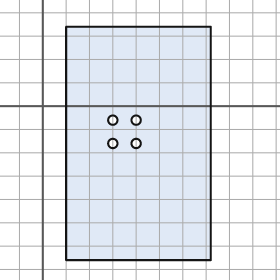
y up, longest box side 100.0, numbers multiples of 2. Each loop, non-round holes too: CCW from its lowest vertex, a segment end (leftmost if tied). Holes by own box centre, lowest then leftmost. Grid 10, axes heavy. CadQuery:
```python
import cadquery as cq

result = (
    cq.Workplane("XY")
    .moveTo(10.0, -66.0)
    .lineTo(72.0, -66.0)
    .lineTo(72.0, 34.0)
    .lineTo(10.0, 34.0)
    .close()
    .moveTo(30.0, -16.0)
    .circle(2.0)
    .moveTo(40.0, -16.0)
    .circle(2.0)
    .moveTo(30.0, -6.0)
    .circle(2.0)
    .moveTo(40.0, -6.0)
    .circle(2.0)
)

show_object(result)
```